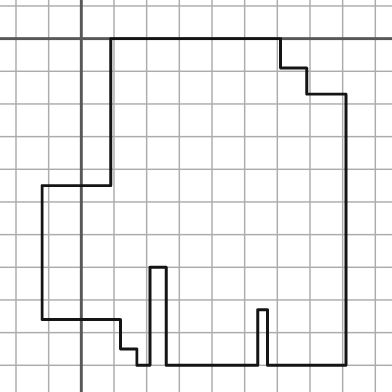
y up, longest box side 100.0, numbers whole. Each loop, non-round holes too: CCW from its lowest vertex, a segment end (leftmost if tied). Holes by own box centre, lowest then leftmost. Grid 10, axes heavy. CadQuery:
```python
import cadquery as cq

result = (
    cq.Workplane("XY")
    .moveTo(17.0, -100.0)
    .lineTo(21.0, -100.0)
    .lineTo(21.0, -70.0)
    .lineTo(26.0, -70.0)
    .lineTo(26.0, -100.0)
    .lineTo(54.0, -100.0)
    .lineTo(54.0, -83.0)
    .lineTo(57.0, -83.0)
    .lineTo(57.0, -100.0)
    .lineTo(81.0, -100.0)
    .lineTo(81.0, -17.0)
    .lineTo(69.0, -17.0)
    .lineTo(69.0, -9.0)
    .lineTo(61.0, -9.0)
    .lineTo(61.0, 0.0)
    .lineTo(9.0, 0.0)
    .lineTo(9.0, -45.0)
    .lineTo(-12.0, -45.0)
    .lineTo(-12.0, -86.0)
    .lineTo(12.0, -86.0)
    .lineTo(12.0, -95.0)
    .lineTo(17.0, -95.0)
    .close()
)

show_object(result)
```